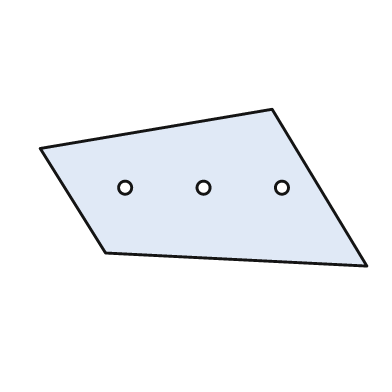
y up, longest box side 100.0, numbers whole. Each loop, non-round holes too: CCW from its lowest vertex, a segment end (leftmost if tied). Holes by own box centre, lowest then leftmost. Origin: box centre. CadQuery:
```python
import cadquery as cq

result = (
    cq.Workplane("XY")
    .moveTo(50.0, -24.0)
    .lineTo(21.0, 24.0)
    .lineTo(-50.0, 12.0)
    .lineTo(-30.0, -20.0)
    .close()
    .moveTo(-24.0, 0.0)
    .circle(2.0)
    .moveTo(0.0, 0.0)
    .circle(2.0)
    .moveTo(24.0, 0.0)
    .circle(2.0)
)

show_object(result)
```